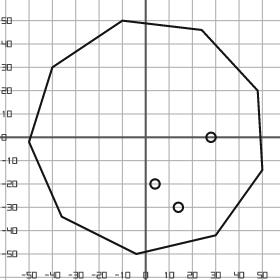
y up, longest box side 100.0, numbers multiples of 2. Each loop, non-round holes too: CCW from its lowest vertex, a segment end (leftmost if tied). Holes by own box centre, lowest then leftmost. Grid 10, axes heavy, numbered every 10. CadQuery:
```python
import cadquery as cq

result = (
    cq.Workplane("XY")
    .moveTo(-4.0, -50.0)
    .lineTo(30.0, -42.0)
    .lineTo(50.0, -14.0)
    .lineTo(48.0, 20.0)
    .lineTo(24.0, 46.0)
    .lineTo(-10.0, 50.0)
    .lineTo(-40.0, 30.0)
    .lineTo(-50.0, -2.0)
    .lineTo(-36.0, -34.0)
    .close()
    .moveTo(14.0, -30.0)
    .circle(2.0)
    .moveTo(4.0, -20.0)
    .circle(2.0)
    .moveTo(28.0, 0.0)
    .circle(2.0)
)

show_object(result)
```